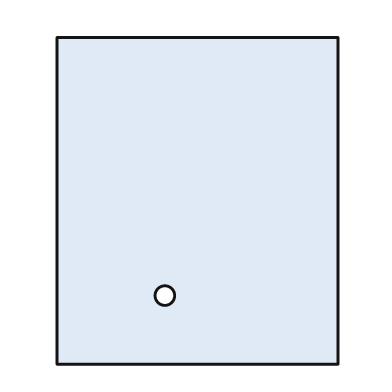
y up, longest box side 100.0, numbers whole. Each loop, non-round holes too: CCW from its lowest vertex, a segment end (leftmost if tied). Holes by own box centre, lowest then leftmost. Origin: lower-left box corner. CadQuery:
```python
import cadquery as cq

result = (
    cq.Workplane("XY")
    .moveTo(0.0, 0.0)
    .lineTo(86.0, 0.0)
    .lineTo(86.0, 100.0)
    .lineTo(0.0, 100.0)
    .close()
    .moveTo(33.0, 21.0)
    .circle(3.0)
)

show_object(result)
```